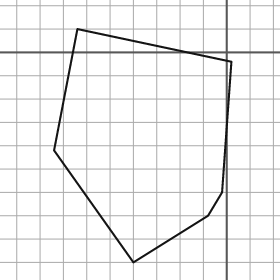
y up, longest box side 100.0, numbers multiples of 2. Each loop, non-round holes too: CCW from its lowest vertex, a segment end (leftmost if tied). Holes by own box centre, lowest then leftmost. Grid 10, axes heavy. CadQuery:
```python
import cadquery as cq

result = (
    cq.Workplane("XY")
    .moveTo(-40.0, -90.0)
    .lineTo(-8.0, -70.0)
    .lineTo(-2.0, -60.0)
    .lineTo(2.0, -4.0)
    .lineTo(-64.0, 10.0)
    .lineTo(-74.0, -42.0)
    .close()
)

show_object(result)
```